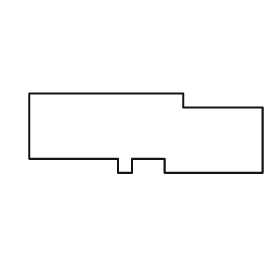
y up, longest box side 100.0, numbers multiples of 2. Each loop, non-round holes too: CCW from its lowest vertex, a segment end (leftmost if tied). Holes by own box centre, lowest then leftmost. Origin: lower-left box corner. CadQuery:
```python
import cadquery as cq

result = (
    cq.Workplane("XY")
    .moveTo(38.0, 0.0)
    .lineTo(44.0, 0.0)
    .lineTo(44.0, 6.0)
    .lineTo(58.0, 6.0)
    .lineTo(58.0, 0.0)
    .lineTo(100.0, 0.0)
    .lineTo(100.0, 28.0)
    .lineTo(66.0, 28.0)
    .lineTo(66.0, 34.0)
    .lineTo(0.0, 34.0)
    .lineTo(0.0, 6.0)
    .lineTo(38.0, 6.0)
    .close()
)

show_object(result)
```